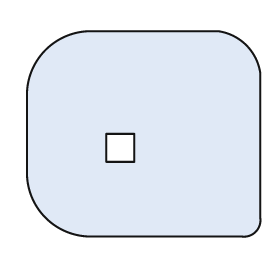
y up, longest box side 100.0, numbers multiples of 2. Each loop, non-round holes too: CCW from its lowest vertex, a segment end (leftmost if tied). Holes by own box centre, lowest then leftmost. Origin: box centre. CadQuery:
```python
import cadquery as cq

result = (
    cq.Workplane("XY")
    .moveTo(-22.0, -44.0)
    .lineTo(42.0, -44.0)
    .threePointArc((48.0, -42.0), (50.0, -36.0))
    .lineTo(50.0, 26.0)
    .threePointArc((44.0, 38.0), (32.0, 44.0))
    .lineTo(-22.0, 44.0)
    .threePointArc((-42.0, 36.0), (-50.0, 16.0))
    .lineTo(-50.0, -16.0)
    .threePointArc((-42.0, -36.0), (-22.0, -44.0))
    .close()
    .moveTo(-16.0, -12.0)
    .lineTo(-4.0, -12.0)
    .lineTo(-4.0, 0.0)
    .lineTo(-16.0, 0.0)
    .close()
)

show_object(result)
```